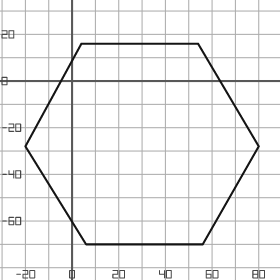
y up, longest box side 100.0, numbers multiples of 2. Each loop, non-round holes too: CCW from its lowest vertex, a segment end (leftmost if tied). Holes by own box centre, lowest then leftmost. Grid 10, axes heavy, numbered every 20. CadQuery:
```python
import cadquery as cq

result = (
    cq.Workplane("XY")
    .moveTo(6.0, -70.0)
    .lineTo(56.0, -70.0)
    .lineTo(80.0, -28.0)
    .lineTo(54.0, 16.0)
    .lineTo(4.0, 16.0)
    .lineTo(-20.0, -28.0)
    .close()
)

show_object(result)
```